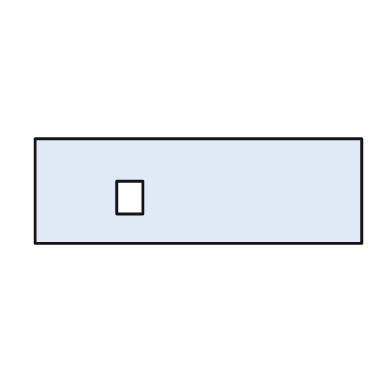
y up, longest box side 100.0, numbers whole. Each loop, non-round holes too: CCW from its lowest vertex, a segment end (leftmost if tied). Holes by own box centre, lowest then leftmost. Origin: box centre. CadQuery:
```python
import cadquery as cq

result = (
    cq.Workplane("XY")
    .moveTo(-50.0, -16.0)
    .lineTo(50.0, -16.0)
    .lineTo(50.0, 16.0)
    .lineTo(-50.0, 16.0)
    .close()
    .moveTo(-25.0, -7.0)
    .lineTo(-17.0, -7.0)
    .lineTo(-17.0, 3.0)
    .lineTo(-25.0, 3.0)
    .close()
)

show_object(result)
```